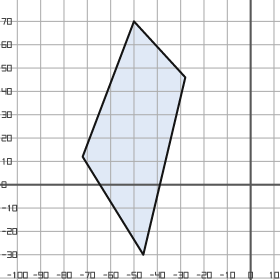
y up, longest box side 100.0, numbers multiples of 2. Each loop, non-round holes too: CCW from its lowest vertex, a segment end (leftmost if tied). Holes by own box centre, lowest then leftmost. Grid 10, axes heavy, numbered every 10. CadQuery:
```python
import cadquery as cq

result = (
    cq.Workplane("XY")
    .moveTo(-46.0, -30.0)
    .lineTo(-28.0, 46.0)
    .lineTo(-50.0, 70.0)
    .lineTo(-72.0, 12.0)
    .close()
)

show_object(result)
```